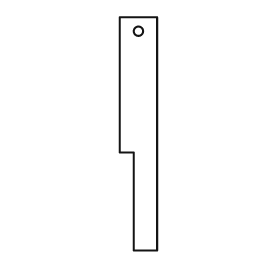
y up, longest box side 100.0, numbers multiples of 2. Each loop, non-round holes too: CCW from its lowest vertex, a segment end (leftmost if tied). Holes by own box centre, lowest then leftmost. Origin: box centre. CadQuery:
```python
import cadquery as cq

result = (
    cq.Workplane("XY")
    .moveTo(-2.0, -50.0)
    .lineTo(8.0, -50.0)
    .lineTo(8.0, 50.0)
    .lineTo(-8.0, 50.0)
    .lineTo(-8.0, -8.0)
    .lineTo(-2.0, -8.0)
    .close()
    .moveTo(0.0, 44.0)
    .circle(2.0)
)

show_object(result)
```